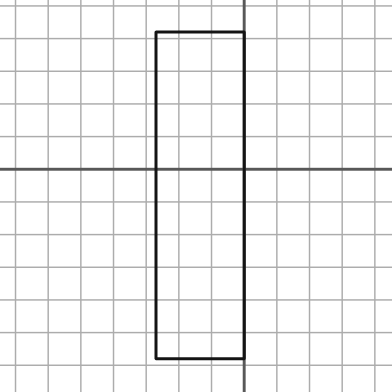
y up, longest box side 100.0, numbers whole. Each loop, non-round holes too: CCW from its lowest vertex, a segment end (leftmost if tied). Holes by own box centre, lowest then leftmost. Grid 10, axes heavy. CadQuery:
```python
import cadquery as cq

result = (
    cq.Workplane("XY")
    .moveTo(-27.0, -58.0)
    .lineTo(0.0, -58.0)
    .lineTo(0.0, 42.0)
    .lineTo(-27.0, 42.0)
    .close()
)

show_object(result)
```